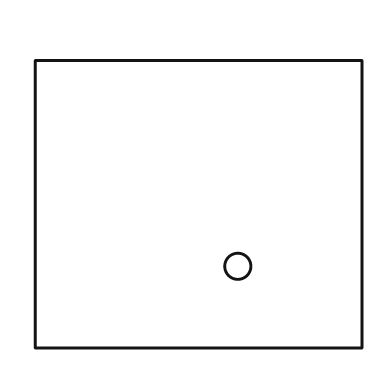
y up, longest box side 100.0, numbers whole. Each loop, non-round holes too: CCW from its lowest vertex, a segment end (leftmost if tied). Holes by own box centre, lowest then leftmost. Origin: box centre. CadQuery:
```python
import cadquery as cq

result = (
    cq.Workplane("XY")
    .moveTo(-50.0, -44.0)
    .lineTo(50.0, -44.0)
    .lineTo(50.0, 44.0)
    .lineTo(-50.0, 44.0)
    .close()
    .moveTo(12.0, -19.0)
    .circle(4.0)
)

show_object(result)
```